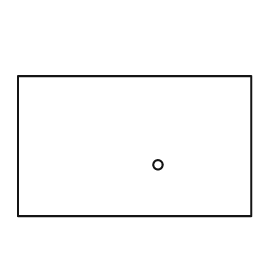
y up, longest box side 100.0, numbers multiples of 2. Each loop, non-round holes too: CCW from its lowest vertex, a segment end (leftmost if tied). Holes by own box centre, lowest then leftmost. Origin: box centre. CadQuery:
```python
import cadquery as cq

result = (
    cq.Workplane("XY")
    .moveTo(-50.0, -30.0)
    .lineTo(50.0, -30.0)
    .lineTo(50.0, 30.0)
    .lineTo(-50.0, 30.0)
    .close()
    .moveTo(10.0, -8.0)
    .circle(2.0)
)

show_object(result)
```